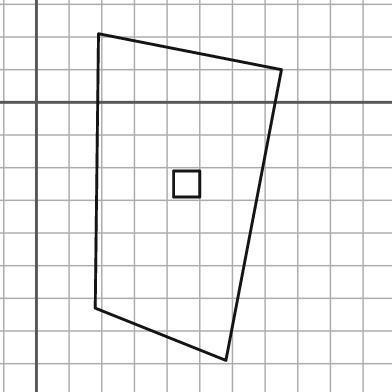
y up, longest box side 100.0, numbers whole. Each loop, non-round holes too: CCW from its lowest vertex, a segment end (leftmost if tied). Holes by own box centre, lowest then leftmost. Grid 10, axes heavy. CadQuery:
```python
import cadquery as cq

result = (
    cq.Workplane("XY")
    .moveTo(58.0, -79.0)
    .lineTo(75.0, 10.0)
    .lineTo(19.0, 21.0)
    .lineTo(18.0, -63.0)
    .close()
    .moveTo(42.0, -29.0)
    .lineTo(50.0, -29.0)
    .lineTo(50.0, -21.0)
    .lineTo(42.0, -21.0)
    .close()
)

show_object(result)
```